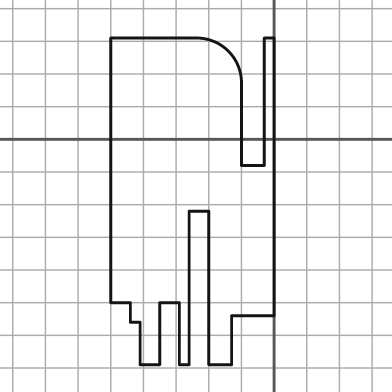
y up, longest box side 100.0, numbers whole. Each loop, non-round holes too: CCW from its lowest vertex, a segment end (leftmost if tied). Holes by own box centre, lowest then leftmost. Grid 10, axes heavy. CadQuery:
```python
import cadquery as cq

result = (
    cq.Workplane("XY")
    .moveTo(-41.0, -69.0)
    .lineTo(-35.0, -69.0)
    .lineTo(-35.0, -50.0)
    .lineTo(-29.0, -50.0)
    .lineTo(-29.0, -69.0)
    .lineTo(-26.0, -69.0)
    .lineTo(-26.0, -22.0)
    .lineTo(-20.0, -22.0)
    .lineTo(-20.0, -69.0)
    .lineTo(-13.0, -69.0)
    .lineTo(-13.0, -54.0)
    .lineTo(0.0, -54.0)
    .lineTo(0.0, 31.0)
    .lineTo(-3.0, 31.0)
    .lineTo(-3.0, -8.0)
    .lineTo(-10.0, -8.0)
    .lineTo(-10.0, 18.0)
    .threePointArc((-14.0, 27.0), (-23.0, 31.0))
    .lineTo(-50.0, 31.0)
    .lineTo(-50.0, -50.0)
    .lineTo(-44.0, -50.0)
    .lineTo(-44.0, -56.0)
    .lineTo(-41.0, -56.0)
    .close()
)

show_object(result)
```